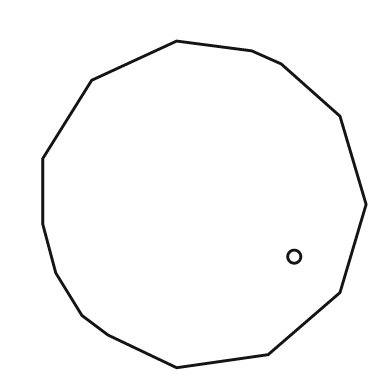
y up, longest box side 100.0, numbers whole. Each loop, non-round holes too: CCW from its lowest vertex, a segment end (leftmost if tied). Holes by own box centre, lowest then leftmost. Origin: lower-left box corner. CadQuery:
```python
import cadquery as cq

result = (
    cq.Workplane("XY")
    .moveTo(41.0, 0.0)
    .lineTo(69.0, 4.0)
    .lineTo(91.0, 23.0)
    .lineTo(99.0, 50.0)
    .lineTo(91.0, 77.0)
    .lineTo(73.0, 93.0)
    .lineTo(64.0, 97.0)
    .lineTo(41.0, 100.0)
    .lineTo(15.0, 88.0)
    .lineTo(0.0, 64.0)
    .lineTo(0.0, 44.0)
    .lineTo(4.0, 29.0)
    .lineTo(12.0, 16.0)
    .lineTo(20.0, 10.0)
    .close()
    .moveTo(77.0, 34.0)
    .circle(2.0)
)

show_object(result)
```